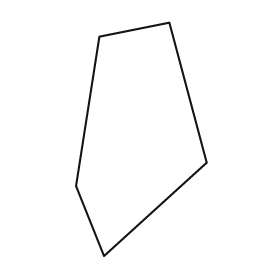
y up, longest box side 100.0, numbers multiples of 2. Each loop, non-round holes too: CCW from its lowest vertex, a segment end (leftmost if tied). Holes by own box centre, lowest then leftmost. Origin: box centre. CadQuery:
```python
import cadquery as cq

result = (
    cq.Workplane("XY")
    .moveTo(-16.0, -50.0)
    .lineTo(28.0, -10.0)
    .lineTo(12.0, 50.0)
    .lineTo(-18.0, 44.0)
    .lineTo(-28.0, -20.0)
    .close()
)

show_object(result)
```